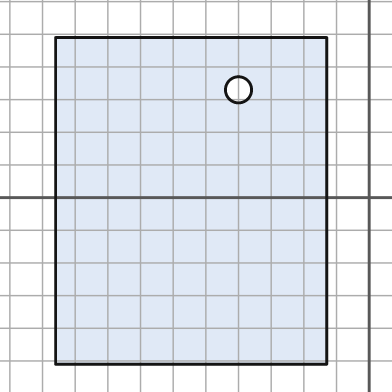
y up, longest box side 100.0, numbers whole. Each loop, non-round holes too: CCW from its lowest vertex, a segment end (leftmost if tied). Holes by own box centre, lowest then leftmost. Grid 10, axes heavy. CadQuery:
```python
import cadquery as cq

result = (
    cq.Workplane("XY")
    .moveTo(-96.0, -51.0)
    .lineTo(-13.0, -51.0)
    .lineTo(-13.0, 49.0)
    .lineTo(-96.0, 49.0)
    .close()
    .moveTo(-40.0, 33.0)
    .circle(4.0)
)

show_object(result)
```